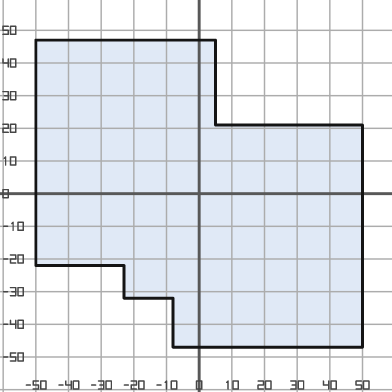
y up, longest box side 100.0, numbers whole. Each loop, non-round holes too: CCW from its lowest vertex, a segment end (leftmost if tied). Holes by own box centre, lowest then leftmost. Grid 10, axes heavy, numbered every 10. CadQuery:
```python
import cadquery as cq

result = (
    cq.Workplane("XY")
    .moveTo(-8.0, -47.0)
    .lineTo(50.0, -47.0)
    .lineTo(50.0, 21.0)
    .lineTo(5.0, 21.0)
    .lineTo(5.0, 47.0)
    .lineTo(-50.0, 47.0)
    .lineTo(-50.0, -22.0)
    .lineTo(-23.0, -22.0)
    .lineTo(-23.0, -32.0)
    .lineTo(-8.0, -32.0)
    .close()
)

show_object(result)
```